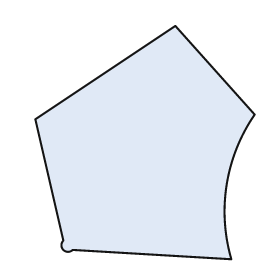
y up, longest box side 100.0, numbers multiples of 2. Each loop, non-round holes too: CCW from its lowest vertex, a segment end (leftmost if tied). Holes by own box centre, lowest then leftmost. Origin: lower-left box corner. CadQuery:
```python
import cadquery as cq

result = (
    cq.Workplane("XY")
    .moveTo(84.0, 0.0)
    .threePointArc((82.0, 32.0), (94.0, 62.0))
    .lineTo(60.0, 100.0)
    .lineTo(0.0, 60.0)
    .lineTo(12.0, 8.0)
    .threePointArc((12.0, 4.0), (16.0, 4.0))
    .close()
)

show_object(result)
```